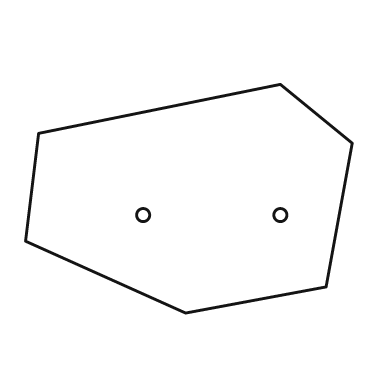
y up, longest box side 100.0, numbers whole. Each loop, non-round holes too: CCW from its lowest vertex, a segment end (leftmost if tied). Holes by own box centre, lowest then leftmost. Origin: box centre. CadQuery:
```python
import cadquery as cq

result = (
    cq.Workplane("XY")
    .moveTo(-1.0, -35.0)
    .lineTo(42.0, -27.0)
    .lineTo(50.0, 17.0)
    .lineTo(28.0, 35.0)
    .lineTo(-46.0, 20.0)
    .lineTo(-50.0, -13.0)
    .close()
    .moveTo(-14.0, -5.0)
    .circle(2.0)
    .moveTo(28.0, -5.0)
    .circle(2.0)
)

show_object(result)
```